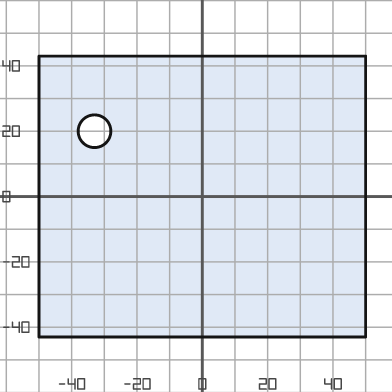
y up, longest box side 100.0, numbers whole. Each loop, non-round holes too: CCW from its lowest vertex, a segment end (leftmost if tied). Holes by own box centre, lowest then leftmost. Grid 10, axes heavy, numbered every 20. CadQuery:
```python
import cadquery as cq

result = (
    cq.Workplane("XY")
    .moveTo(-50.0, -43.0)
    .lineTo(50.0, -43.0)
    .lineTo(50.0, 43.0)
    .lineTo(-50.0, 43.0)
    .close()
    .moveTo(-33.0, 20.0)
    .circle(5.0)
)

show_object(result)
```